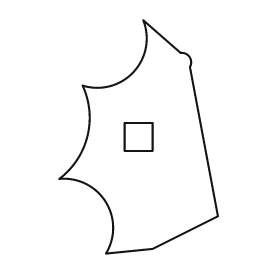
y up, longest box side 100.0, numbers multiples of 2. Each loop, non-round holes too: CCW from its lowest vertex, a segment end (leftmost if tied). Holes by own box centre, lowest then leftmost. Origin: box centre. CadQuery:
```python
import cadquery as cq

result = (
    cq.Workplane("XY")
    .moveTo(-14.0, -50.0)
    .lineTo(6.0, -48.0)
    .lineTo(34.0, -34.0)
    .lineTo(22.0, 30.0)
    .threePointArc((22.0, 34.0), (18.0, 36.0))
    .lineTo(2.0, 50.0)
    .threePointArc((-2.0, 28.0), (-24.0, 22.0))
    .threePointArc((-22.0, 0.0), (-34.0, -18.0))
    .threePointArc((-14.0, -28.0), (-14.0, -50.0))
    .close()
    .moveTo(-6.0, -6.0)
    .lineTo(6.0, -6.0)
    .lineTo(6.0, 6.0)
    .lineTo(-6.0, 6.0)
    .close()
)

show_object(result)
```